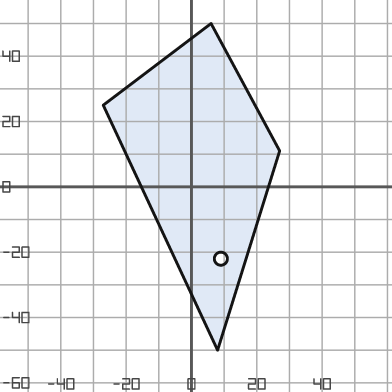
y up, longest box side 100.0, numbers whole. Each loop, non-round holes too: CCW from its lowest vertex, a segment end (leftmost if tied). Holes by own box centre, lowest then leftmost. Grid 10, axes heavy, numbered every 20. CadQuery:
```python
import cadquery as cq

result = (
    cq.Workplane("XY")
    .moveTo(8.0, -50.0)
    .lineTo(27.0, 11.0)
    .lineTo(6.0, 50.0)
    .lineTo(-27.0, 25.0)
    .close()
    .moveTo(9.0, -22.0)
    .circle(2.0)
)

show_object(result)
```